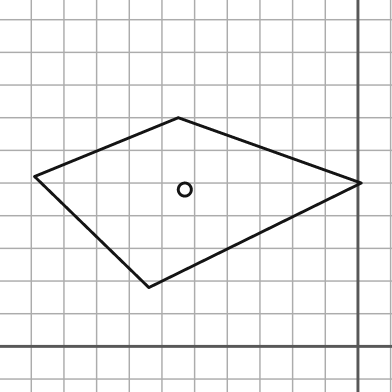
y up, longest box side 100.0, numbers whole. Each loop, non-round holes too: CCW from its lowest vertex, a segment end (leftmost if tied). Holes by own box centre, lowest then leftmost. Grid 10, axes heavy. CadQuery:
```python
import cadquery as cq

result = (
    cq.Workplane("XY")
    .moveTo(-64.0, 18.0)
    .lineTo(1.0, 50.0)
    .lineTo(-55.0, 70.0)
    .lineTo(-99.0, 52.0)
    .close()
    .moveTo(-53.0, 48.0)
    .circle(2.0)
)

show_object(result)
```